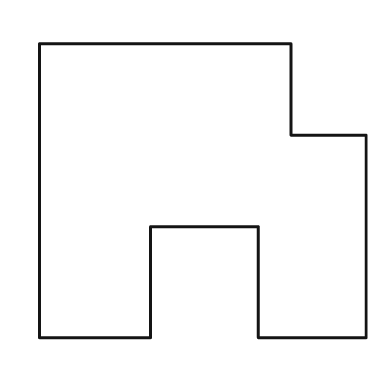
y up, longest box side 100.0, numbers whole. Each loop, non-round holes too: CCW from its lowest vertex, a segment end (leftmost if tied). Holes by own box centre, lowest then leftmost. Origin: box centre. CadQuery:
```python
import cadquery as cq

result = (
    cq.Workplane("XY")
    .moveTo(-50.0, -45.0)
    .lineTo(-16.0, -45.0)
    .lineTo(-16.0, -11.0)
    .lineTo(17.0, -11.0)
    .lineTo(17.0, -45.0)
    .lineTo(50.0, -45.0)
    .lineTo(50.0, 17.0)
    .lineTo(27.0, 17.0)
    .lineTo(27.0, 45.0)
    .lineTo(-50.0, 45.0)
    .close()
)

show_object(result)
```